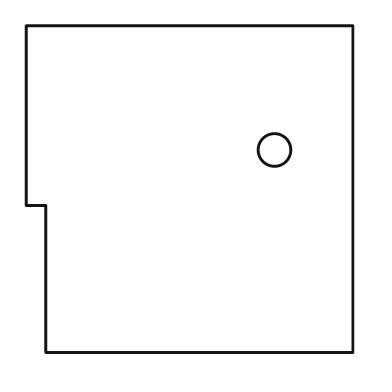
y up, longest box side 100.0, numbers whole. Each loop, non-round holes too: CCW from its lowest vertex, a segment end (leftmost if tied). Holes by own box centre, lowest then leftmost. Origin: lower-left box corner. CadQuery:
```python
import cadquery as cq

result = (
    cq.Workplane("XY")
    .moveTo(6.0, 0.0)
    .lineTo(100.0, 0.0)
    .lineTo(100.0, 100.0)
    .lineTo(0.0, 100.0)
    .lineTo(0.0, 45.0)
    .lineTo(6.0, 45.0)
    .close()
    .moveTo(76.0, 62.0)
    .circle(5.0)
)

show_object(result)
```